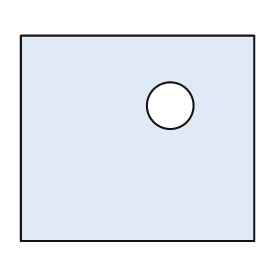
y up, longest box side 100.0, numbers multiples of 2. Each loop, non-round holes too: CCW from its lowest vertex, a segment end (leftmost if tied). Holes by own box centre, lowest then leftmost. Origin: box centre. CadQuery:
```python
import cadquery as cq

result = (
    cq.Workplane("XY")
    .moveTo(-50.0, -44.0)
    .lineTo(50.0, -44.0)
    .lineTo(50.0, 44.0)
    .lineTo(-50.0, 44.0)
    .close()
    .moveTo(14.0, 14.0)
    .circle(10.0)
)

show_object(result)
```